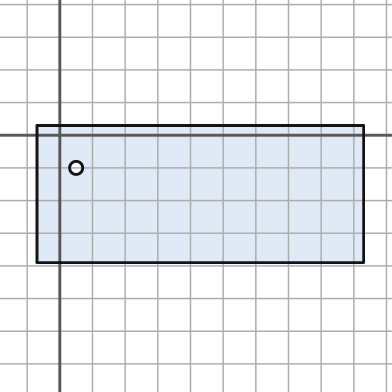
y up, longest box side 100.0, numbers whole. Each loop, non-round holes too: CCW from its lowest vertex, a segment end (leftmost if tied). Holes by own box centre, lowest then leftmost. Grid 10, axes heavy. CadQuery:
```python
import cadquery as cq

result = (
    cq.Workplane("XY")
    .moveTo(-7.0, -39.0)
    .lineTo(93.0, -39.0)
    .lineTo(93.0, 3.0)
    .lineTo(-7.0, 3.0)
    .close()
    .moveTo(5.0, -10.0)
    .circle(2.0)
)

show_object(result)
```